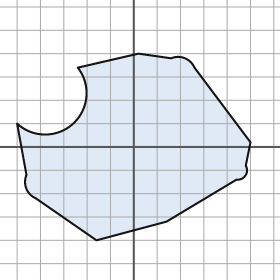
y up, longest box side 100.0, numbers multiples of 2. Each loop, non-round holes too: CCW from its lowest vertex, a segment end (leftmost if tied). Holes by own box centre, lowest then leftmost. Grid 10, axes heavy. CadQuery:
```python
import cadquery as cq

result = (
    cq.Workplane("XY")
    .moveTo(-16.0, -40.0)
    .lineTo(14.0, -32.0)
    .lineTo(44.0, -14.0)
    .threePointArc((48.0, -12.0), (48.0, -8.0))
    .lineTo(50.0, 2.0)
    .lineTo(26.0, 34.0)
    .threePointArc((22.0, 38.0), (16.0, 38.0))
    .lineTo(2.0, 40.0)
    .lineTo(-24.0, 34.0)
    .threePointArc((-26.0, 10.0), (-50.0, 10.0))
    .lineTo(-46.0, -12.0)
    .threePointArc((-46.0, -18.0), (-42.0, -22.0))
    .close()
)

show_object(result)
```